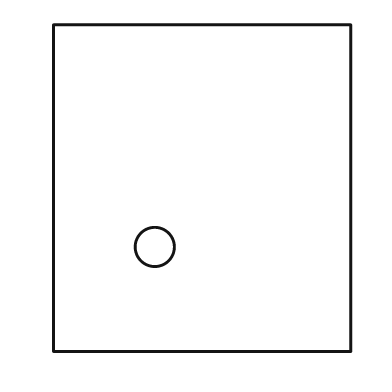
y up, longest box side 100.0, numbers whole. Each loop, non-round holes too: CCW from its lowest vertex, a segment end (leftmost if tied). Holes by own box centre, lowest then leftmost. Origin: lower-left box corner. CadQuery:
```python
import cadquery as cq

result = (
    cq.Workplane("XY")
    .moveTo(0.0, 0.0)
    .lineTo(91.0, 0.0)
    .lineTo(91.0, 100.0)
    .lineTo(0.0, 100.0)
    .close()
    .moveTo(31.0, 32.0)
    .circle(6.0)
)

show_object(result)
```